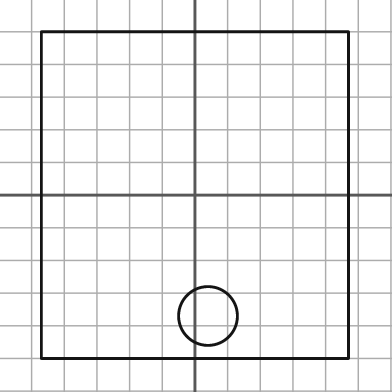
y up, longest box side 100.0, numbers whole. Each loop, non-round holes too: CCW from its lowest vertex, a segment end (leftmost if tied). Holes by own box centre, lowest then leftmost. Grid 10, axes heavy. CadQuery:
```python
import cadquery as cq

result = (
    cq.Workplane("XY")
    .moveTo(-47.0, -50.0)
    .lineTo(47.0, -50.0)
    .lineTo(47.0, 50.0)
    .lineTo(-47.0, 50.0)
    .close()
    .moveTo(4.0, -37.0)
    .circle(9.0)
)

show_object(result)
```